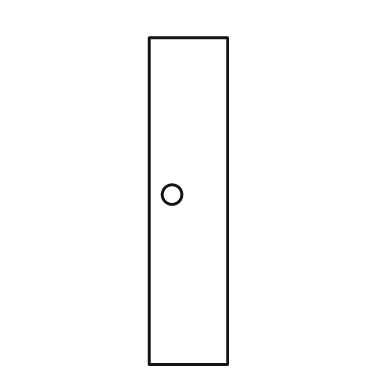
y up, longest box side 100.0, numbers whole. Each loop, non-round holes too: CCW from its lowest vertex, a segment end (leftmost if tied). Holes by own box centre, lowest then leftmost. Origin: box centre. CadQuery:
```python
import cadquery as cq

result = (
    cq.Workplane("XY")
    .moveTo(-12.0, -50.0)
    .lineTo(12.0, -50.0)
    .lineTo(12.0, 50.0)
    .lineTo(-12.0, 50.0)
    .close()
    .moveTo(-5.0, 2.0)
    .circle(3.0)
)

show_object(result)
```